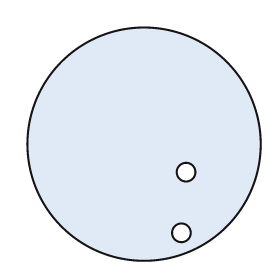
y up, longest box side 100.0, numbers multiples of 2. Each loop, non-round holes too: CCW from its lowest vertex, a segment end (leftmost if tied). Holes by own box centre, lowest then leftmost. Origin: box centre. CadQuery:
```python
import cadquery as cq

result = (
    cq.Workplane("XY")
    .moveTo(0.0, 0.0)
    .circle(50.0)
    .moveTo(16.0, -38.0)
    .circle(4.0)
    .moveTo(18.0, -12.0)
    .circle(4.0)
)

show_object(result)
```